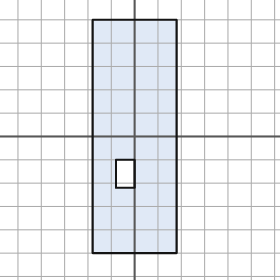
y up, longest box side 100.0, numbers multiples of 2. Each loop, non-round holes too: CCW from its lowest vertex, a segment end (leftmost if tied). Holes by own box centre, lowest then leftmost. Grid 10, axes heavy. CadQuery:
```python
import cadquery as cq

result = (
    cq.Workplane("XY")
    .moveTo(-18.0, -50.0)
    .lineTo(18.0, -50.0)
    .lineTo(18.0, 50.0)
    .lineTo(-18.0, 50.0)
    .close()
    .moveTo(-8.0, -22.0)
    .lineTo(0.0, -22.0)
    .lineTo(0.0, -10.0)
    .lineTo(-8.0, -10.0)
    .close()
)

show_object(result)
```